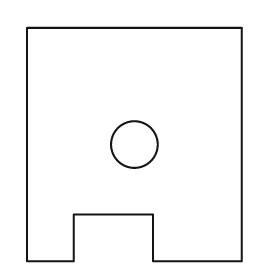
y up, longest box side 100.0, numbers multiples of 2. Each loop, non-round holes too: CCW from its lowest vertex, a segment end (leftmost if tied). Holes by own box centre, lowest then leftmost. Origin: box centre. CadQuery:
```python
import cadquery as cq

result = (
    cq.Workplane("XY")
    .moveTo(-46.0, -50.0)
    .lineTo(-26.0, -50.0)
    .lineTo(-26.0, -30.0)
    .lineTo(8.0, -30.0)
    .lineTo(8.0, -50.0)
    .lineTo(46.0, -50.0)
    .lineTo(46.0, 50.0)
    .lineTo(-46.0, 50.0)
    .close()
    .moveTo(0.0, 0.0)
    .circle(10.0)
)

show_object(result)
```